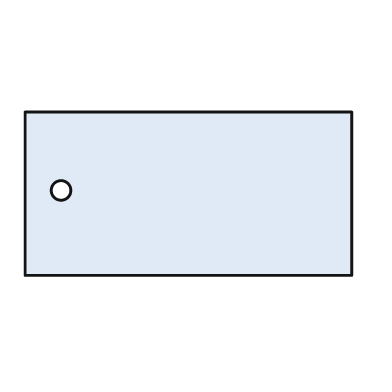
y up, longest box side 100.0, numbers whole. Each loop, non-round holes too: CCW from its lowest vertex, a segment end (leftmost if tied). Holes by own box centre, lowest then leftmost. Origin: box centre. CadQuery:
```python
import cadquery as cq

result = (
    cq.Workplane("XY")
    .moveTo(-50.0, -25.0)
    .lineTo(50.0, -25.0)
    .lineTo(50.0, 25.0)
    .lineTo(-50.0, 25.0)
    .close()
    .moveTo(-39.0, 1.0)
    .circle(3.0)
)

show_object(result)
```